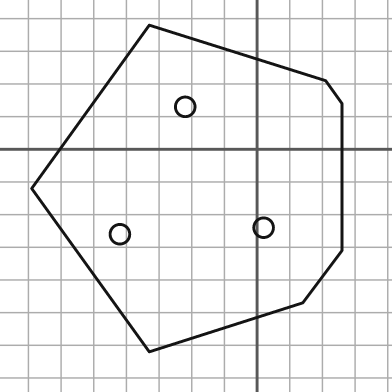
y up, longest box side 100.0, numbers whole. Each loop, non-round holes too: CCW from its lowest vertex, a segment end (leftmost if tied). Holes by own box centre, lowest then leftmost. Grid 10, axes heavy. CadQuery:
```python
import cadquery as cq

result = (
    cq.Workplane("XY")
    .moveTo(-33.0, -62.0)
    .lineTo(14.0, -47.0)
    .lineTo(26.0, -31.0)
    .lineTo(26.0, 14.0)
    .lineTo(21.0, 21.0)
    .lineTo(-33.0, 38.0)
    .lineTo(-69.0, -12.0)
    .close()
    .moveTo(-42.0, -26.0)
    .circle(3.0)
    .moveTo(2.0, -24.0)
    .circle(3.0)
    .moveTo(-22.0, 13.0)
    .circle(3.0)
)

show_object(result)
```